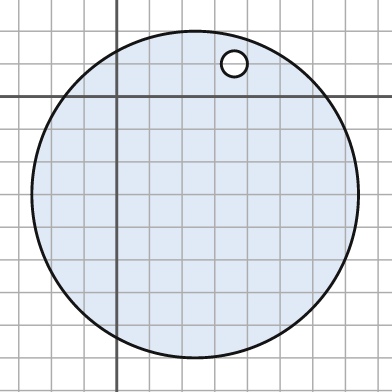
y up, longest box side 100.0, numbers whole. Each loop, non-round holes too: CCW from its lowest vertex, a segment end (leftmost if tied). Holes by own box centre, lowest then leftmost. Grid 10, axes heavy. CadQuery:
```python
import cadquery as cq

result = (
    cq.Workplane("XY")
    .moveTo(24.0, -30.0)
    .circle(50.0)
    .moveTo(36.0, 10.0)
    .circle(4.0)
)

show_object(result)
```